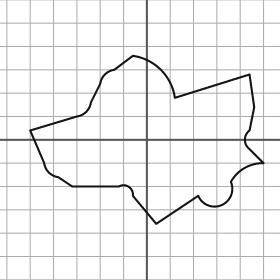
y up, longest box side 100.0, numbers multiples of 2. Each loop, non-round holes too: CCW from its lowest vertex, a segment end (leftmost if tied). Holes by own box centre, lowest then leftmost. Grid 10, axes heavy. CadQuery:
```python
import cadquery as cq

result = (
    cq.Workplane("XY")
    .moveTo(4.0, -36.0)
    .lineTo(22.0, -24.0)
    .threePointArc((32.0, -28.0), (36.0, -18.0))
    .threePointArc((42.0, -12.0), (50.0, -10.0))
    .lineTo(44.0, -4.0)
    .threePointArc((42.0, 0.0), (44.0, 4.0))
    .lineTo(46.0, 14.0)
    .lineTo(44.0, 28.0)
    .lineTo(12.0, 18.0)
    .threePointArc((6.0, 30.0), (-6.0, 36.0))
    .lineTo(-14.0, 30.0)
    .threePointArc((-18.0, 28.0), (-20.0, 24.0))
    .lineTo(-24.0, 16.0)
    .threePointArc((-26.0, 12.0), (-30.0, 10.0))
    .lineTo(-50.0, 4.0)
    .lineTo(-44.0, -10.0)
    .threePointArc((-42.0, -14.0), (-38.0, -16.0))
    .lineTo(-32.0, -20.0)
    .lineTo(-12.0, -20.0)
    .threePointArc((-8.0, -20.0), (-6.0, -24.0))
    .close()
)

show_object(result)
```